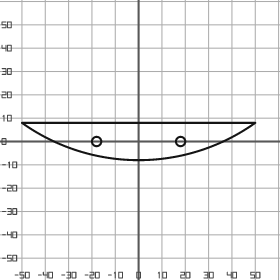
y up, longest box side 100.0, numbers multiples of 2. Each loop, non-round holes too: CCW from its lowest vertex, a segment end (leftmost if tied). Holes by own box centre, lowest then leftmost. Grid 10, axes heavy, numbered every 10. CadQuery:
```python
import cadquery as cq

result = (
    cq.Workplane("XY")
    .moveTo(-50.0, 8.0)
    .threePointArc((0.0, -8.0), (50.0, 8.0))
    .close()
    .moveTo(-18.0, 0.0)
    .circle(2.0)
    .moveTo(18.0, 0.0)
    .circle(2.0)
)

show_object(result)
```